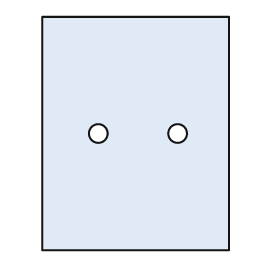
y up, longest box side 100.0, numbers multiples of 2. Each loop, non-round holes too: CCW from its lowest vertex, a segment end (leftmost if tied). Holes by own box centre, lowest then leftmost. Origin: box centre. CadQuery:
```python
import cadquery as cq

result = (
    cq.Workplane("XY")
    .moveTo(-40.0, -50.0)
    .lineTo(40.0, -50.0)
    .lineTo(40.0, 50.0)
    .lineTo(-40.0, 50.0)
    .close()
    .moveTo(-16.0, 0.0)
    .circle(4.0)
    .moveTo(18.0, 0.0)
    .circle(4.0)
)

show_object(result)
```